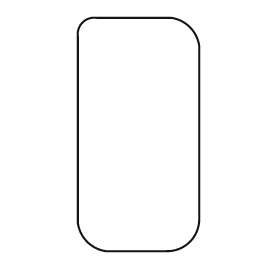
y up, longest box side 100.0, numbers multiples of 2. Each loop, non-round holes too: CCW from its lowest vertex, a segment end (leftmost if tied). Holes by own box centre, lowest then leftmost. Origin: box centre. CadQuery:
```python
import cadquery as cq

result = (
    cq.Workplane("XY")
    .moveTo(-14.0, -50.0)
    .lineTo(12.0, -50.0)
    .threePointArc((22.0, -46.0), (26.0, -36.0))
    .lineTo(26.0, 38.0)
    .threePointArc((22.0, 46.0), (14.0, 50.0))
    .lineTo(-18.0, 50.0)
    .threePointArc((-24.0, 48.0), (-26.0, 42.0))
    .lineTo(-26.0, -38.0)
    .threePointArc((-22.0, -46.0), (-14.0, -50.0))
    .close()
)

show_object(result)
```